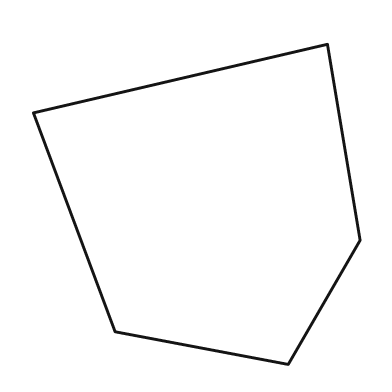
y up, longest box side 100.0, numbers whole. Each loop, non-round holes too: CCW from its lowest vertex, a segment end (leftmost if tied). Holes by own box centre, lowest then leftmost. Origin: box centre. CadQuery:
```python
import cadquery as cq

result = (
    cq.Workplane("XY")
    .moveTo(28.0, -49.0)
    .lineTo(50.0, -11.0)
    .lineTo(40.0, 49.0)
    .lineTo(-50.0, 28.0)
    .lineTo(-25.0, -39.0)
    .close()
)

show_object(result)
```